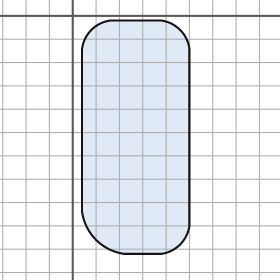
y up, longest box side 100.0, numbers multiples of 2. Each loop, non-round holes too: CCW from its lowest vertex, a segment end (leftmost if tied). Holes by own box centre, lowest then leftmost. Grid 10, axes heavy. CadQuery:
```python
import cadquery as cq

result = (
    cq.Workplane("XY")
    .moveTo(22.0, -102.0)
    .lineTo(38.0, -102.0)
    .threePointArc((46.0, -98.0), (50.0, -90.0))
    .lineTo(50.0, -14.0)
    .threePointArc((46.0, -6.0), (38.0, -2.0))
    .lineTo(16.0, -2.0)
    .threePointArc((8.0, -6.0), (4.0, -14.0))
    .lineTo(4.0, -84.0)
    .threePointArc((10.0, -96.0), (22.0, -102.0))
    .close()
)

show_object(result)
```